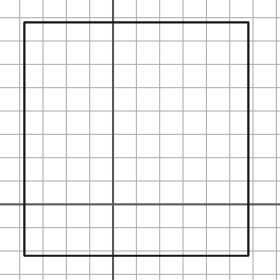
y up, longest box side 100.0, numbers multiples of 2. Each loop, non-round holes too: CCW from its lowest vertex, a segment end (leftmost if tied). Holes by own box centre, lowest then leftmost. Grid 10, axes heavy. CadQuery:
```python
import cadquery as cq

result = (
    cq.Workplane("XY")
    .moveTo(-38.0, -22.0)
    .lineTo(58.0, -22.0)
    .lineTo(58.0, 78.0)
    .lineTo(-38.0, 78.0)
    .close()
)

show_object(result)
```